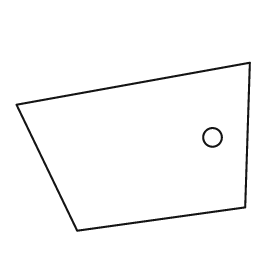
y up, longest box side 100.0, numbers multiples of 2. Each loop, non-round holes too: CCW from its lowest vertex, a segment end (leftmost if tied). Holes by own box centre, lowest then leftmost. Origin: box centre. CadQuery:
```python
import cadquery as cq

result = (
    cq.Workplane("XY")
    .moveTo(-24.0, -36.0)
    .lineTo(48.0, -26.0)
    .lineTo(50.0, 36.0)
    .lineTo(-50.0, 18.0)
    .close()
    .moveTo(34.0, 4.0)
    .circle(4.0)
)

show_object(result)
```